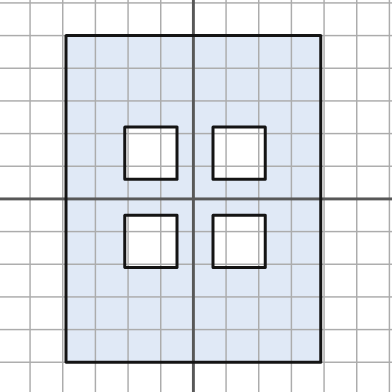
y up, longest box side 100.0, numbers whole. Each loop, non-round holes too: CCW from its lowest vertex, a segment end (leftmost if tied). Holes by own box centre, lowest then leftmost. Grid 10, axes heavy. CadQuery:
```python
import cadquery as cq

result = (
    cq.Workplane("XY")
    .moveTo(-39.0, -50.0)
    .lineTo(39.0, -50.0)
    .lineTo(39.0, 50.0)
    .lineTo(-39.0, 50.0)
    .close()
    .moveTo(-21.0, -21.0)
    .lineTo(-5.0, -21.0)
    .lineTo(-5.0, -5.0)
    .lineTo(-21.0, -5.0)
    .close()
    .moveTo(6.0, -21.0)
    .lineTo(22.0, -21.0)
    .lineTo(22.0, -5.0)
    .lineTo(6.0, -5.0)
    .close()
    .moveTo(-21.0, 6.0)
    .lineTo(-5.0, 6.0)
    .lineTo(-5.0, 22.0)
    .lineTo(-21.0, 22.0)
    .close()
    .moveTo(6.0, 6.0)
    .lineTo(22.0, 6.0)
    .lineTo(22.0, 22.0)
    .lineTo(6.0, 22.0)
    .close()
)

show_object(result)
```